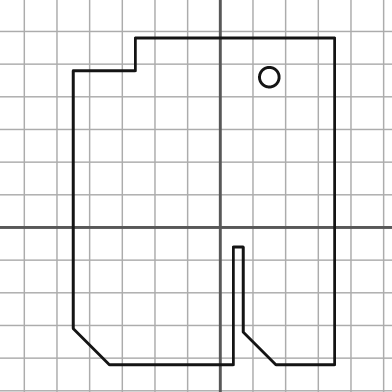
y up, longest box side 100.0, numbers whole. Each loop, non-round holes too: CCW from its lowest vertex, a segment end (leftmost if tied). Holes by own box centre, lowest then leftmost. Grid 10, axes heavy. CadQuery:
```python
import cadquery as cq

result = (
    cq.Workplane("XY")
    .moveTo(-34.0, -42.0)
    .lineTo(4.0, -42.0)
    .lineTo(4.0, -6.0)
    .lineTo(7.0, -6.0)
    .lineTo(7.0, -32.0)
    .lineTo(17.0, -42.0)
    .lineTo(35.0, -42.0)
    .lineTo(35.0, 58.0)
    .lineTo(-26.0, 58.0)
    .lineTo(-26.0, 48.0)
    .lineTo(-45.0, 48.0)
    .lineTo(-45.0, -31.0)
    .close()
    .moveTo(15.0, 46.0)
    .circle(3.0)
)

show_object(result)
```